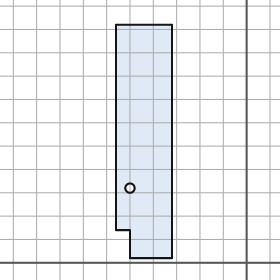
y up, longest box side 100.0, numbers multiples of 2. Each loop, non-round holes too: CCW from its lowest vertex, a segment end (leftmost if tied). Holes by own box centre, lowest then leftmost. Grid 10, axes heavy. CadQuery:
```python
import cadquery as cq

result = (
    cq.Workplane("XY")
    .moveTo(-50.0, 2.0)
    .lineTo(-32.0, 2.0)
    .lineTo(-32.0, 102.0)
    .lineTo(-56.0, 102.0)
    .lineTo(-56.0, 14.0)
    .lineTo(-50.0, 14.0)
    .close()
    .moveTo(-50.0, 32.0)
    .circle(2.0)
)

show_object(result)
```